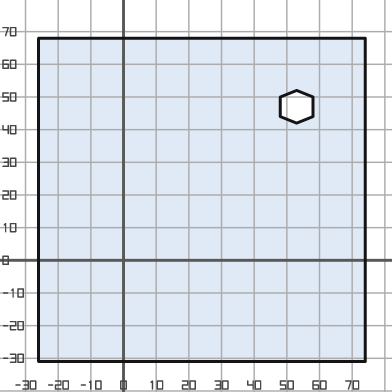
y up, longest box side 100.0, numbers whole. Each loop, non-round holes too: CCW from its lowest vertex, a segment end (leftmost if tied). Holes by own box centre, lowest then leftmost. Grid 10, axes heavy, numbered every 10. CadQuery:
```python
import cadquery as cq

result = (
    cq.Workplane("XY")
    .moveTo(-26.0, -31.0)
    .lineTo(74.0, -31.0)
    .lineTo(74.0, 68.0)
    .lineTo(-26.0, 68.0)
    .close()
    .moveTo(53.0, 42.0)
    .lineTo(58.0, 44.0)
    .lineTo(58.0, 50.0)
    .lineTo(53.0, 52.0)
    .lineTo(48.0, 50.0)
    .lineTo(48.0, 44.0)
    .close()
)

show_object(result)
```